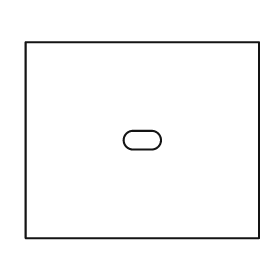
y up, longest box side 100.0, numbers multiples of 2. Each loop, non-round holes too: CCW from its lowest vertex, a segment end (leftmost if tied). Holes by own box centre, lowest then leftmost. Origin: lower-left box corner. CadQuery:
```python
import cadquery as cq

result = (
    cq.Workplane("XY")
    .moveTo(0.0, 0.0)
    .lineTo(100.0, 0.0)
    .lineTo(100.0, 84.0)
    .lineTo(0.0, 84.0)
    .close()
    .moveTo(46.0, 38.0)
    .lineTo(54.0, 38.0)
    .threePointArc((58.0, 42.0), (54.0, 46.0))
    .lineTo(46.0, 46.0)
    .threePointArc((42.0, 42.0), (46.0, 38.0))
    .close()
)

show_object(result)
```